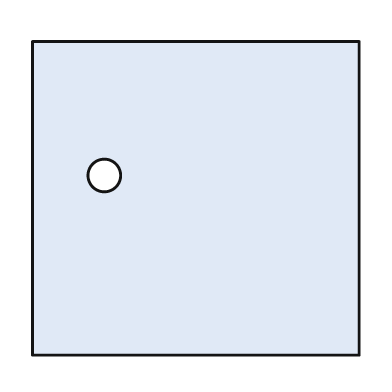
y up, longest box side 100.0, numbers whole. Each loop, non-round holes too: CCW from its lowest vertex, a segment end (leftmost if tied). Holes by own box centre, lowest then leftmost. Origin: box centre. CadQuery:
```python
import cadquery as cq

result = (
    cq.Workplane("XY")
    .moveTo(-50.0, -48.0)
    .lineTo(50.0, -48.0)
    .lineTo(50.0, 48.0)
    .lineTo(-50.0, 48.0)
    .close()
    .moveTo(-28.0, 7.0)
    .circle(5.0)
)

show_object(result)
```